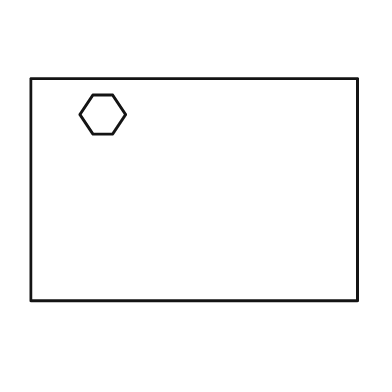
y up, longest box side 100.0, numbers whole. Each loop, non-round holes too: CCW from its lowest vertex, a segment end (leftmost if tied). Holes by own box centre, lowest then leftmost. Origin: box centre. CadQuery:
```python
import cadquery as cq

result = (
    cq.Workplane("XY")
    .moveTo(-50.0, -34.0)
    .lineTo(50.0, -34.0)
    .lineTo(50.0, 34.0)
    .lineTo(-50.0, 34.0)
    .close()
    .moveTo(-31.0, 17.0)
    .lineTo(-25.0, 17.0)
    .lineTo(-21.0, 23.0)
    .lineTo(-25.0, 29.0)
    .lineTo(-31.0, 29.0)
    .lineTo(-35.0, 23.0)
    .close()
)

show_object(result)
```